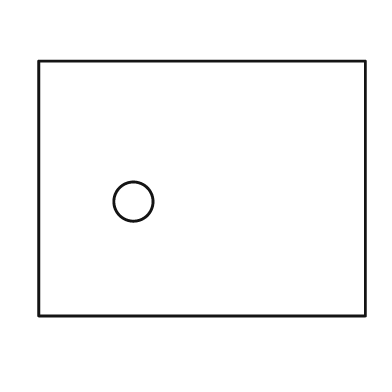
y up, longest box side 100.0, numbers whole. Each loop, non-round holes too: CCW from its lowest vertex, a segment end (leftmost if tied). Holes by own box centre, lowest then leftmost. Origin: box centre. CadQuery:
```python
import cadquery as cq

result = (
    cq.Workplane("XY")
    .moveTo(-50.0, -39.0)
    .lineTo(50.0, -39.0)
    .lineTo(50.0, 39.0)
    .lineTo(-50.0, 39.0)
    .close()
    .moveTo(-21.0, -4.0)
    .circle(6.0)
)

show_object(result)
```